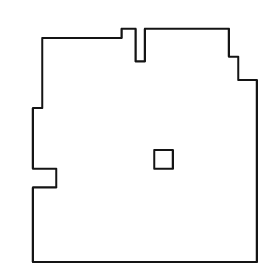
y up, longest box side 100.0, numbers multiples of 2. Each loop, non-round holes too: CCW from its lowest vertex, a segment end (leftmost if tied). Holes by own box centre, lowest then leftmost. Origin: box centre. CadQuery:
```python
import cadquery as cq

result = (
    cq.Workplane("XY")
    .moveTo(-48.0, -50.0)
    .lineTo(48.0, -50.0)
    .lineTo(48.0, 28.0)
    .lineTo(40.0, 28.0)
    .lineTo(40.0, 38.0)
    .lineTo(36.0, 38.0)
    .lineTo(36.0, 50.0)
    .lineTo(0.0, 50.0)
    .lineTo(0.0, 36.0)
    .lineTo(-4.0, 36.0)
    .lineTo(-4.0, 50.0)
    .lineTo(-10.0, 50.0)
    .lineTo(-10.0, 46.0)
    .lineTo(-44.0, 46.0)
    .lineTo(-44.0, 16.0)
    .lineTo(-48.0, 16.0)
    .lineTo(-48.0, -10.0)
    .lineTo(-38.0, -10.0)
    .lineTo(-38.0, -18.0)
    .lineTo(-48.0, -18.0)
    .close()
    .moveTo(4.0, -10.0)
    .lineTo(12.0, -10.0)
    .lineTo(12.0, -2.0)
    .lineTo(4.0, -2.0)
    .close()
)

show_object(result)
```